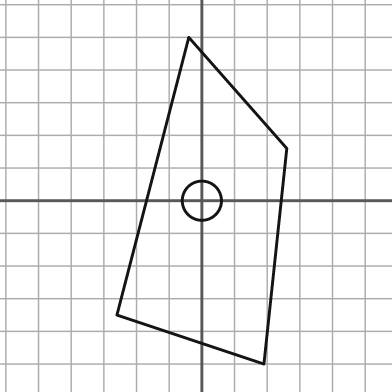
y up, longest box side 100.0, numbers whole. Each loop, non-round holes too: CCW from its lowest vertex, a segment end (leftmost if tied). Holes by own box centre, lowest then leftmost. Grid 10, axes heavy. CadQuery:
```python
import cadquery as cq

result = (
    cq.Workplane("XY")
    .moveTo(19.0, -50.0)
    .lineTo(26.0, 16.0)
    .lineTo(-4.0, 50.0)
    .lineTo(-26.0, -35.0)
    .close()
    .moveTo(0.0, 0.0)
    .circle(6.0)
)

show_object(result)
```